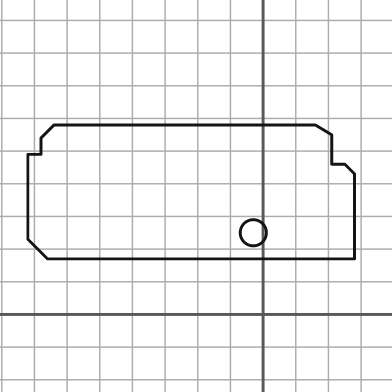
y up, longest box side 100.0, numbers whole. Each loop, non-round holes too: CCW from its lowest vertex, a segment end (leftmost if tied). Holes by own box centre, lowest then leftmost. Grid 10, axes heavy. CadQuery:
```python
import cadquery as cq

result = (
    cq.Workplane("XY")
    .moveTo(-66.0, 17.0)
    .lineTo(28.0, 17.0)
    .lineTo(28.0, 43.0)
    .lineTo(25.0, 46.0)
    .lineTo(21.0, 46.0)
    .lineTo(21.0, 55.0)
    .lineTo(16.0, 58.0)
    .lineTo(-64.0, 58.0)
    .lineTo(-68.0, 54.0)
    .lineTo(-68.0, 49.0)
    .lineTo(-72.0, 49.0)
    .lineTo(-72.0, 23.0)
    .close()
    .moveTo(-3.0, 25.0)
    .circle(4.0)
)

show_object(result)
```